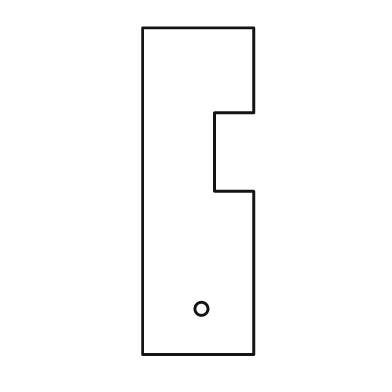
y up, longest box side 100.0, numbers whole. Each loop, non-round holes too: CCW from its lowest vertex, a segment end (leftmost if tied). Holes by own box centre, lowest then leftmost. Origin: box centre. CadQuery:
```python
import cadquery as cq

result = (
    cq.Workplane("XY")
    .moveTo(-17.0, -50.0)
    .lineTo(17.0, -50.0)
    .lineTo(17.0, 0.0)
    .lineTo(5.0, 0.0)
    .lineTo(5.0, 24.0)
    .lineTo(17.0, 24.0)
    .lineTo(17.0, 50.0)
    .lineTo(-17.0, 50.0)
    .close()
    .moveTo(1.0, -36.0)
    .circle(2.0)
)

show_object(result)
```